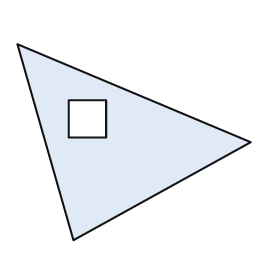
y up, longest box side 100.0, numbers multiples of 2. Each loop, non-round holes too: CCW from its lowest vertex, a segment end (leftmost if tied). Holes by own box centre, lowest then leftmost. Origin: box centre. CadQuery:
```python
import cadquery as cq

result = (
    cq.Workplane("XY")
    .moveTo(-26.0, -42.0)
    .lineTo(50.0, 0.0)
    .lineTo(-50.0, 42.0)
    .close()
    .moveTo(-28.0, 2.0)
    .lineTo(-12.0, 2.0)
    .lineTo(-12.0, 18.0)
    .lineTo(-28.0, 18.0)
    .close()
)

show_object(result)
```